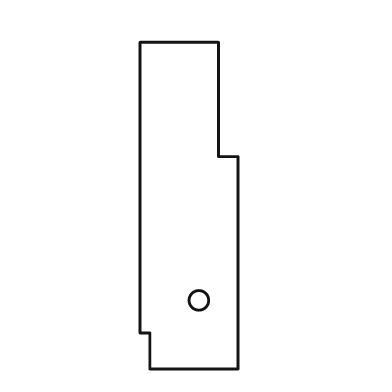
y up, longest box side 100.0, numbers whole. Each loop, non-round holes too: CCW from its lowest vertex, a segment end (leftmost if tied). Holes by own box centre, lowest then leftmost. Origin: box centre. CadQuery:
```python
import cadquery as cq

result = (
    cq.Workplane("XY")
    .moveTo(-12.0, -50.0)
    .lineTo(15.0, -50.0)
    .lineTo(15.0, 15.0)
    .lineTo(9.0, 15.0)
    .lineTo(9.0, 50.0)
    .lineTo(-15.0, 50.0)
    .lineTo(-15.0, -39.0)
    .lineTo(-12.0, -39.0)
    .close()
    .moveTo(3.0, -29.0)
    .circle(3.0)
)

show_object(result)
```